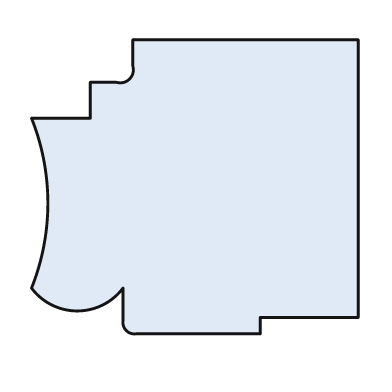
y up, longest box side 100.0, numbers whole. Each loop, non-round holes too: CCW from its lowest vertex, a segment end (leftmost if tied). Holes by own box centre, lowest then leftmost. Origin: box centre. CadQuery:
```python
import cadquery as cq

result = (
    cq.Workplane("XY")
    .moveTo(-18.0, -45.0)
    .lineTo(20.0, -45.0)
    .lineTo(20.0, -40.0)
    .lineTo(50.0, -40.0)
    .lineTo(50.0, 45.0)
    .lineTo(-19.0, 45.0)
    .lineTo(-19.0, 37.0)
    .threePointArc((-20.0, 33.0), (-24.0, 32.0))
    .lineTo(-32.0, 32.0)
    .lineTo(-32.0, 21.0)
    .lineTo(-50.0, 21.0)
    .threePointArc((-45.0, -5.0), (-50.0, -31.0))
    .threePointArc((-36.0, -38.0), (-22.0, -31.0))
    .lineTo(-22.0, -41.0)
    .threePointArc((-21.0, -44.0), (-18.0, -45.0))
    .close()
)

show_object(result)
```